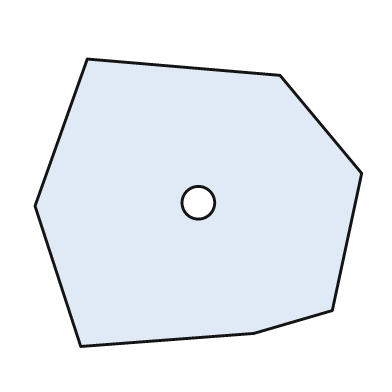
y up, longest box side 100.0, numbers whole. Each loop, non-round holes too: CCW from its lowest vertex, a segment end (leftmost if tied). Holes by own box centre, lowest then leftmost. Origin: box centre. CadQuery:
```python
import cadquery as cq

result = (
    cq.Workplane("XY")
    .moveTo(-36.0, -44.0)
    .lineTo(17.0, -40.0)
    .lineTo(41.0, -33.0)
    .lineTo(50.0, 9.0)
    .lineTo(25.0, 39.0)
    .lineTo(-34.0, 44.0)
    .lineTo(-50.0, -1.0)
    .close()
    .moveTo(0.0, 0.0)
    .circle(5.0)
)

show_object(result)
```